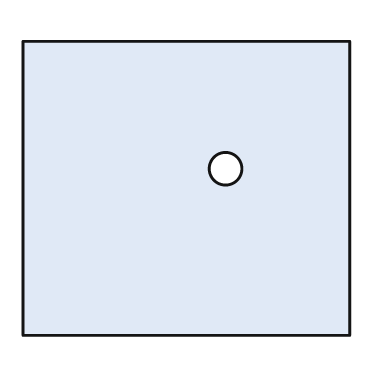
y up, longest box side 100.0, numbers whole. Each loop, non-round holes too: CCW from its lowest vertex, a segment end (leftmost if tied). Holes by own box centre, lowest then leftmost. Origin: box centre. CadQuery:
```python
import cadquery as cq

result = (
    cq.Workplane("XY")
    .moveTo(-50.0, -45.0)
    .lineTo(50.0, -45.0)
    .lineTo(50.0, 45.0)
    .lineTo(-50.0, 45.0)
    .close()
    .moveTo(12.0, 6.0)
    .circle(5.0)
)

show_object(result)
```